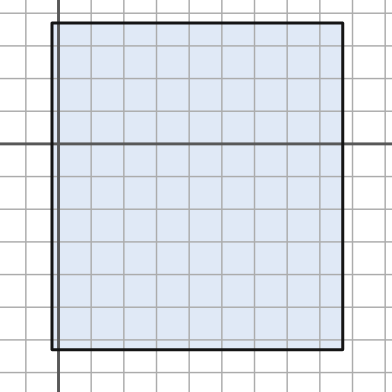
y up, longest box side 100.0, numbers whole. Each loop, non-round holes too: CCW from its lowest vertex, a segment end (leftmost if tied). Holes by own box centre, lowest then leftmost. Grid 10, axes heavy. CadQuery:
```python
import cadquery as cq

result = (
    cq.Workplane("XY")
    .moveTo(-2.0, -63.0)
    .lineTo(87.0, -63.0)
    .lineTo(87.0, 37.0)
    .lineTo(-2.0, 37.0)
    .close()
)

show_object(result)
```